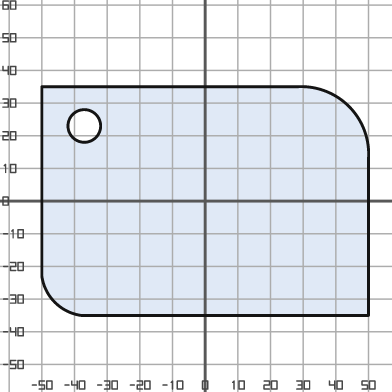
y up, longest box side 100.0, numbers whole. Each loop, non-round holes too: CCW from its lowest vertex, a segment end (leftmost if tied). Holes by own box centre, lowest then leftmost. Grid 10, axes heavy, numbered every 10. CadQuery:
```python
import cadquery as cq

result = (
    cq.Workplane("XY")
    .moveTo(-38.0, -35.0)
    .lineTo(50.0, -35.0)
    .lineTo(50.0, 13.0)
    .threePointArc((44.0, 29.0), (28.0, 35.0))
    .lineTo(-50.0, 35.0)
    .lineTo(-50.0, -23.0)
    .threePointArc((-46.0, -31.0), (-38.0, -35.0))
    .close()
    .moveTo(-37.0, 23.0)
    .circle(5.0)
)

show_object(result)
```